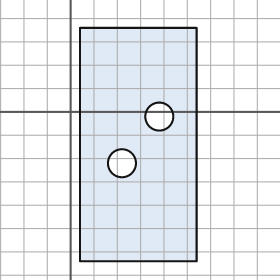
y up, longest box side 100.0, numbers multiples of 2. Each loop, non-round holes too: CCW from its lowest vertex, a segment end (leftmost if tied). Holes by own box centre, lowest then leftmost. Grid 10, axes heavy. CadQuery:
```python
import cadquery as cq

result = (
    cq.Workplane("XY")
    .moveTo(4.0, -64.0)
    .lineTo(54.0, -64.0)
    .lineTo(54.0, 36.0)
    .lineTo(4.0, 36.0)
    .close()
    .moveTo(22.0, -22.0)
    .circle(6.0)
    .moveTo(38.0, -2.0)
    .circle(6.0)
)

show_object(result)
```